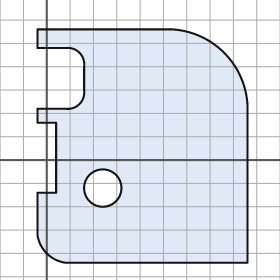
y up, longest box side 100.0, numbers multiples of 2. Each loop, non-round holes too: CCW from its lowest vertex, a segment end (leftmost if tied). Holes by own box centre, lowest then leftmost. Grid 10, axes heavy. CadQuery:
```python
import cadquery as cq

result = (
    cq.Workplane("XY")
    .moveTo(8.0, -44.0)
    .lineTo(86.0, -44.0)
    .lineTo(86.0, 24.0)
    .threePointArc((76.0, 46.0), (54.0, 56.0))
    .lineTo(-4.0, 56.0)
    .lineTo(-4.0, 48.0)
    .lineTo(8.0, 48.0)
    .threePointArc((14.0, 46.0), (16.0, 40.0))
    .lineTo(16.0, 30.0)
    .threePointArc((14.0, 24.0), (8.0, 22.0))
    .lineTo(-4.0, 22.0)
    .lineTo(-4.0, 16.0)
    .lineTo(4.0, 16.0)
    .lineTo(4.0, -14.0)
    .lineTo(-4.0, -14.0)
    .lineTo(-4.0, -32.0)
    .threePointArc((0.0, -40.0), (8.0, -44.0))
    .close()
    .moveTo(24.0, -12.0)
    .circle(8.0)
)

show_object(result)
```